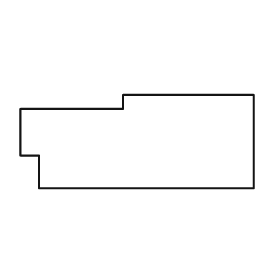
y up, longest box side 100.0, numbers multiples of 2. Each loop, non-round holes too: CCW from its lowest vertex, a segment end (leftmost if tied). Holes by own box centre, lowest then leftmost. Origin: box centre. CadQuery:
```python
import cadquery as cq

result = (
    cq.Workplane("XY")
    .moveTo(-42.0, -20.0)
    .lineTo(50.0, -20.0)
    .lineTo(50.0, 20.0)
    .lineTo(-6.0, 20.0)
    .lineTo(-6.0, 14.0)
    .lineTo(-50.0, 14.0)
    .lineTo(-50.0, -6.0)
    .lineTo(-42.0, -6.0)
    .close()
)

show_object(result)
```